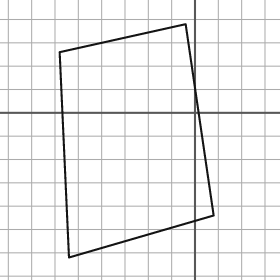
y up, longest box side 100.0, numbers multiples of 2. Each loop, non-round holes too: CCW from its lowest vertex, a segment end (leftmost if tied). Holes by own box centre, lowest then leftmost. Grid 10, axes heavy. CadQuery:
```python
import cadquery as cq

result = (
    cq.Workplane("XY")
    .moveTo(-54.0, -62.0)
    .lineTo(8.0, -44.0)
    .lineTo(-4.0, 38.0)
    .lineTo(-58.0, 26.0)
    .close()
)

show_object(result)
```